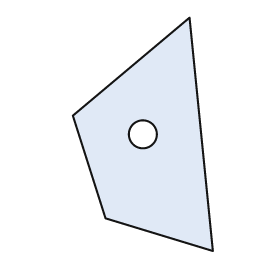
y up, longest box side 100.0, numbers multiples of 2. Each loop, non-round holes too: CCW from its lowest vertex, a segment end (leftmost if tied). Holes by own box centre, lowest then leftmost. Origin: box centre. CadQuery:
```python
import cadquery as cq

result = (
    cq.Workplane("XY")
    .moveTo(30.0, -50.0)
    .lineTo(20.0, 50.0)
    .lineTo(-30.0, 8.0)
    .lineTo(-16.0, -36.0)
    .close()
    .moveTo(0.0, 0.0)
    .circle(6.0)
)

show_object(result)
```